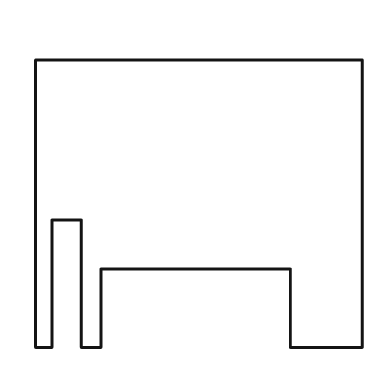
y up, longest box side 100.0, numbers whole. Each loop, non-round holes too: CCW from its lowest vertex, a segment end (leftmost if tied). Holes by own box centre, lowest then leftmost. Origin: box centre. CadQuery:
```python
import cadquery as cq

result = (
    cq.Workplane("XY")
    .moveTo(-50.0, -44.0)
    .lineTo(-45.0, -44.0)
    .lineTo(-45.0, -5.0)
    .lineTo(-36.0, -5.0)
    .lineTo(-36.0, -44.0)
    .lineTo(-30.0, -44.0)
    .lineTo(-30.0, -20.0)
    .lineTo(28.0, -20.0)
    .lineTo(28.0, -44.0)
    .lineTo(50.0, -44.0)
    .lineTo(50.0, 44.0)
    .lineTo(-50.0, 44.0)
    .close()
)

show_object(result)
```